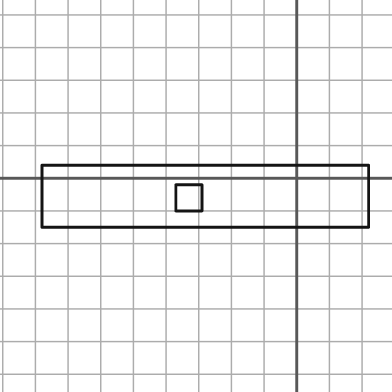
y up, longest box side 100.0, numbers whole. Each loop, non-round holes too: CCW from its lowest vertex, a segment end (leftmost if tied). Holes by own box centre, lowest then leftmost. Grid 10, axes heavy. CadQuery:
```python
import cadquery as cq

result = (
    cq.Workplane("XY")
    .moveTo(-78.0, -15.0)
    .lineTo(22.0, -15.0)
    .lineTo(22.0, 4.0)
    .lineTo(-78.0, 4.0)
    .close()
    .moveTo(-37.0, -10.0)
    .lineTo(-29.0, -10.0)
    .lineTo(-29.0, -2.0)
    .lineTo(-37.0, -2.0)
    .close()
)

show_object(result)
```